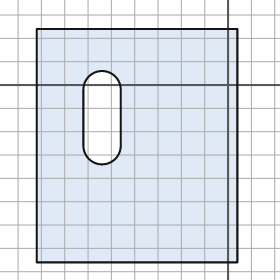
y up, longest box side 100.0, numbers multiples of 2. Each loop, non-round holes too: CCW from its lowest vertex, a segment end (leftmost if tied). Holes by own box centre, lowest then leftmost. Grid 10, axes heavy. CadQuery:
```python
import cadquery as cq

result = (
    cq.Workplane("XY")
    .moveTo(-82.0, -76.0)
    .lineTo(4.0, -76.0)
    .lineTo(4.0, 24.0)
    .lineTo(-82.0, 24.0)
    .close()
    .moveTo(-62.0, -26.0)
    .threePointArc((-54.0, -34.0), (-46.0, -26.0))
    .lineTo(-46.0, -2.0)
    .threePointArc((-54.0, 6.0), (-62.0, -2.0))
    .close()
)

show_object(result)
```